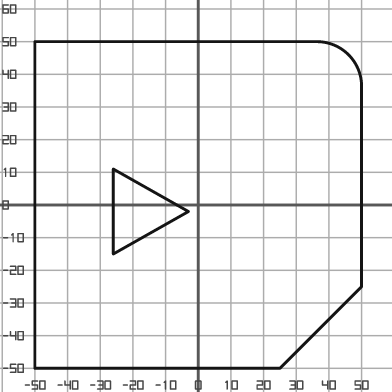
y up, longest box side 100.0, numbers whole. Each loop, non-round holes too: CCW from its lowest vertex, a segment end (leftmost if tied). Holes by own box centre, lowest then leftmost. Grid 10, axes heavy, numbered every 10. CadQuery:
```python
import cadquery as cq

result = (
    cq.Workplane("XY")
    .moveTo(-50.0, -50.0)
    .lineTo(25.0, -50.0)
    .lineTo(50.0, -25.0)
    .lineTo(50.0, 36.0)
    .threePointArc((46.0, 46.0), (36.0, 50.0))
    .lineTo(-50.0, 50.0)
    .close()
    .moveTo(-26.0, -15.0)
    .lineTo(-3.0, -2.0)
    .lineTo(-26.0, 11.0)
    .close()
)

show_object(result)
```